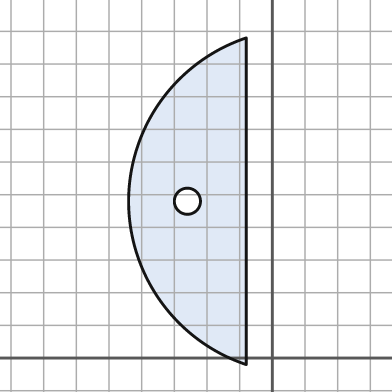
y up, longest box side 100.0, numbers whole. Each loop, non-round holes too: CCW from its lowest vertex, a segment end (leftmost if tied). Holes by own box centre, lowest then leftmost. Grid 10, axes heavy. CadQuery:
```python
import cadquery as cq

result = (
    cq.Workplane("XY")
    .moveTo(-8.0, -2.0)
    .lineTo(-8.0, 98.0)
    .threePointArc((-44.0, 48.0), (-8.0, -2.0))
    .close()
    .moveTo(-26.0, 48.0)
    .circle(4.0)
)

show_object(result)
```